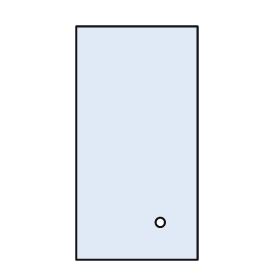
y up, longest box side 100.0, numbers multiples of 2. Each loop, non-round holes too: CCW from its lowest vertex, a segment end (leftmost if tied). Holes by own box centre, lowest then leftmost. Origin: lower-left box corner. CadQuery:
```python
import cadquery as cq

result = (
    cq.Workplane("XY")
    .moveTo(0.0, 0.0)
    .lineTo(52.0, 0.0)
    .lineTo(52.0, 100.0)
    .lineTo(0.0, 100.0)
    .close()
    .moveTo(36.0, 16.0)
    .circle(2.0)
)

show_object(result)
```